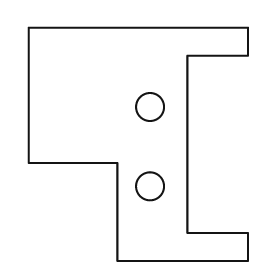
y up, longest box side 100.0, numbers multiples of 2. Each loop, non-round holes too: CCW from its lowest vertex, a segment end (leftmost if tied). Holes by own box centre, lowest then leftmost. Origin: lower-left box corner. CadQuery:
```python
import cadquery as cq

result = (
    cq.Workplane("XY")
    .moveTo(38.0, 0.0)
    .lineTo(94.0, 0.0)
    .lineTo(94.0, 12.0)
    .lineTo(68.0, 12.0)
    .lineTo(68.0, 88.0)
    .lineTo(94.0, 88.0)
    .lineTo(94.0, 100.0)
    .lineTo(0.0, 100.0)
    .lineTo(0.0, 42.0)
    .lineTo(38.0, 42.0)
    .close()
    .moveTo(52.0, 32.0)
    .circle(6.0)
    .moveTo(52.0, 66.0)
    .circle(6.0)
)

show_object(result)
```